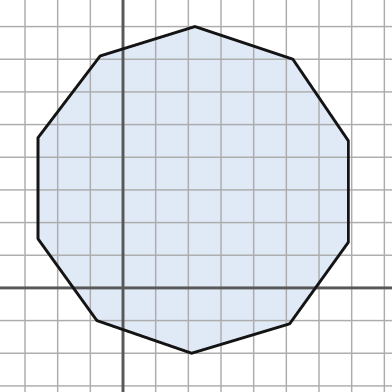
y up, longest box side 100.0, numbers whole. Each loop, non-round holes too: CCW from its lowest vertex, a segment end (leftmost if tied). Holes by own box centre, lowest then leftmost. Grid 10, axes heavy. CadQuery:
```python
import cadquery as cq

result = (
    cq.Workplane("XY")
    .moveTo(21.0, -20.0)
    .lineTo(51.0, -11.0)
    .lineTo(69.0, 14.0)
    .lineTo(69.0, 45.0)
    .lineTo(52.0, 70.0)
    .lineTo(22.0, 80.0)
    .lineTo(-7.0, 71.0)
    .lineTo(-26.0, 46.0)
    .lineTo(-26.0, 15.0)
    .lineTo(-8.0, -10.0)
    .close()
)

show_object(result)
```